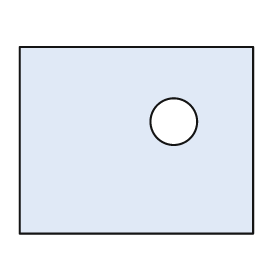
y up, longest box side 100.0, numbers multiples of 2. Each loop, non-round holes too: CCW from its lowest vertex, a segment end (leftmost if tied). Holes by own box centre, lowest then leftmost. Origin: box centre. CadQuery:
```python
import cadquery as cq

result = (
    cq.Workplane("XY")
    .moveTo(-50.0, -40.0)
    .lineTo(50.0, -40.0)
    .lineTo(50.0, 40.0)
    .lineTo(-50.0, 40.0)
    .close()
    .moveTo(16.0, 8.0)
    .circle(10.0)
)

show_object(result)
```